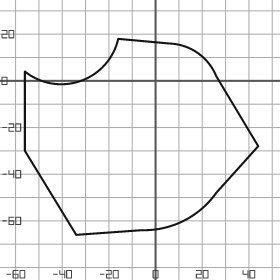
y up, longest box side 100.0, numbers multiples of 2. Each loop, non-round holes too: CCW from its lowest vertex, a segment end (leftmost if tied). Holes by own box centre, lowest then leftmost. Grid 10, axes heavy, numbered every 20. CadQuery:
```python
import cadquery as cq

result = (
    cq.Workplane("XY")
    .moveTo(-34.0, -66.0)
    .lineTo(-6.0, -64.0)
    .threePointArc((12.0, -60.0), (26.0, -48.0))
    .lineTo(44.0, -28.0)
    .lineTo(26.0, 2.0)
    .threePointArc((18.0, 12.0), (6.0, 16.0))
    .lineTo(-16.0, 18.0)
    .threePointArc((-32.0, 0.0), (-56.0, 4.0))
    .lineTo(-56.0, -30.0)
    .close()
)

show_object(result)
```